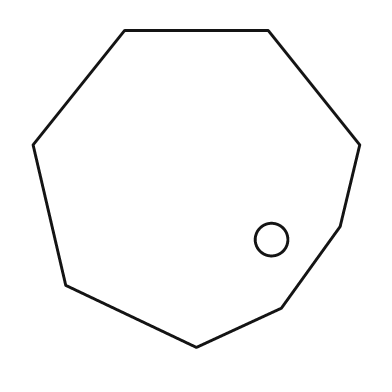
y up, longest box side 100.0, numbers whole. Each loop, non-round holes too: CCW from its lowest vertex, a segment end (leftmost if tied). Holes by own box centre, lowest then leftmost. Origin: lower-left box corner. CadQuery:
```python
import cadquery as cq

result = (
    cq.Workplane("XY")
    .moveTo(50.0, 0.0)
    .lineTo(76.0, 12.0)
    .lineTo(94.0, 37.0)
    .lineTo(100.0, 62.0)
    .lineTo(72.0, 97.0)
    .lineTo(28.0, 97.0)
    .lineTo(0.0, 62.0)
    .lineTo(10.0, 19.0)
    .close()
    .moveTo(73.0, 33.0)
    .circle(5.0)
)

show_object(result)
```